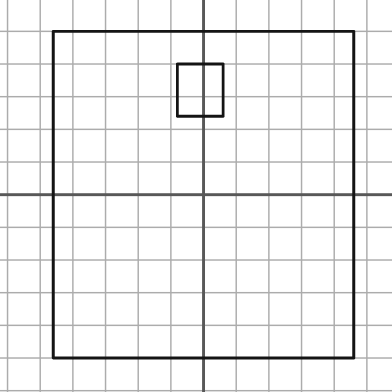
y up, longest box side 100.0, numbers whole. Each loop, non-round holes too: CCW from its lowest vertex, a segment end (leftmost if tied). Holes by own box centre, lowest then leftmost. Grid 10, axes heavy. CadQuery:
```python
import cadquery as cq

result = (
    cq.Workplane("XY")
    .moveTo(-46.0, -50.0)
    .lineTo(46.0, -50.0)
    .lineTo(46.0, 50.0)
    .lineTo(-46.0, 50.0)
    .close()
    .moveTo(-8.0, 24.0)
    .lineTo(6.0, 24.0)
    .lineTo(6.0, 40.0)
    .lineTo(-8.0, 40.0)
    .close()
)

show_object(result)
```